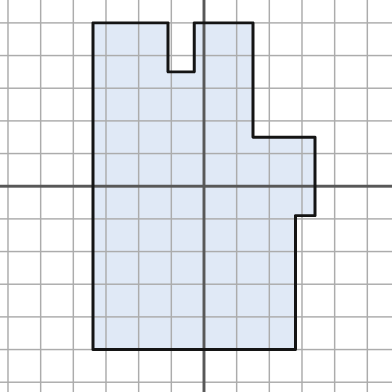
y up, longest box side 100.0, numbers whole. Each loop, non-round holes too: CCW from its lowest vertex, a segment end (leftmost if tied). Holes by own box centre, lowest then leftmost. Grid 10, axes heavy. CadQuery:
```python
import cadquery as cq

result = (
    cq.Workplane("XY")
    .moveTo(-34.0, -50.0)
    .lineTo(28.0, -50.0)
    .lineTo(28.0, -9.0)
    .lineTo(34.0, -9.0)
    .lineTo(34.0, 15.0)
    .lineTo(15.0, 15.0)
    .lineTo(15.0, 50.0)
    .lineTo(-3.0, 50.0)
    .lineTo(-3.0, 35.0)
    .lineTo(-11.0, 35.0)
    .lineTo(-11.0, 50.0)
    .lineTo(-34.0, 50.0)
    .close()
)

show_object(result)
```